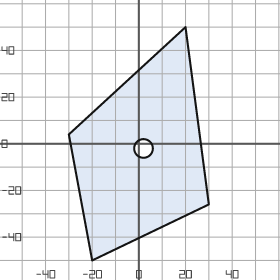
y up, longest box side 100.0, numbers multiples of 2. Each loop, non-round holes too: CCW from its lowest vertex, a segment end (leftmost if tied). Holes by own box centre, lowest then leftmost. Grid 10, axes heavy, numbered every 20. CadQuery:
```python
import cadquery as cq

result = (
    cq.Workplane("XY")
    .moveTo(-20.0, -50.0)
    .lineTo(30.0, -26.0)
    .lineTo(20.0, 50.0)
    .lineTo(-30.0, 4.0)
    .close()
    .moveTo(2.0, -2.0)
    .circle(4.0)
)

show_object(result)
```